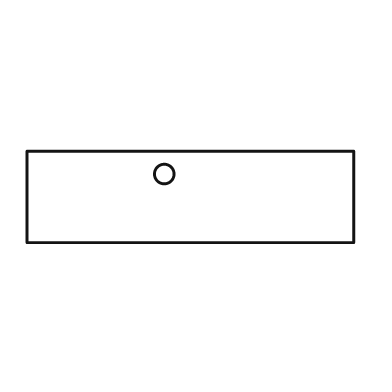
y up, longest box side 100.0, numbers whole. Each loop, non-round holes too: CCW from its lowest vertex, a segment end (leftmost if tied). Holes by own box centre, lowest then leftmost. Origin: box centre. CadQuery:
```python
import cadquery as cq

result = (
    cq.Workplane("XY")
    .moveTo(-50.0, -14.0)
    .lineTo(50.0, -14.0)
    .lineTo(50.0, 14.0)
    .lineTo(-50.0, 14.0)
    .close()
    .moveTo(-8.0, 7.0)
    .circle(3.0)
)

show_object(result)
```